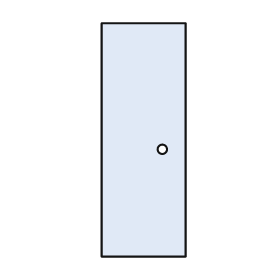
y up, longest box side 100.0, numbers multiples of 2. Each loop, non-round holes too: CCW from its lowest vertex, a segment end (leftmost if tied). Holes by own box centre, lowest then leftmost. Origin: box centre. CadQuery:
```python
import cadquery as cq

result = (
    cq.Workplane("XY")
    .moveTo(-18.0, -50.0)
    .lineTo(18.0, -50.0)
    .lineTo(18.0, 50.0)
    .lineTo(-18.0, 50.0)
    .close()
    .moveTo(8.0, -4.0)
    .circle(2.0)
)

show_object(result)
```